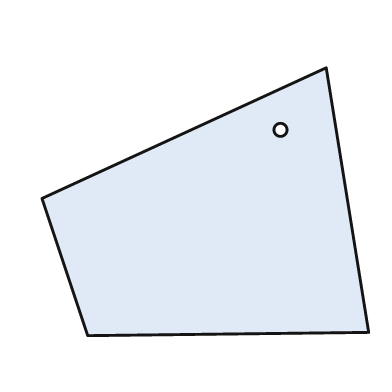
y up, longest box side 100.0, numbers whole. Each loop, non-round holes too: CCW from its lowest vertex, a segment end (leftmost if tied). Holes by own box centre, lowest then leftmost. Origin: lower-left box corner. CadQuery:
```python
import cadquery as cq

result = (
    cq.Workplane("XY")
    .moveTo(14.0, 0.0)
    .lineTo(100.0, 1.0)
    .lineTo(87.0, 82.0)
    .lineTo(0.0, 42.0)
    .close()
    .moveTo(73.0, 63.0)
    .circle(2.0)
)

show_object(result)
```